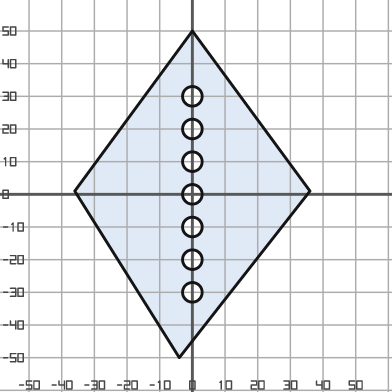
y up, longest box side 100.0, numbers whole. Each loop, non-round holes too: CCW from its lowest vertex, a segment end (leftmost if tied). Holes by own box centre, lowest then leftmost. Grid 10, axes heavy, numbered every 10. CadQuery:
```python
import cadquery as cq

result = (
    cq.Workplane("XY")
    .moveTo(-4.0, -50.0)
    .lineTo(36.0, 1.0)
    .lineTo(0.0, 50.0)
    .lineTo(-36.0, 1.0)
    .close()
    .moveTo(0.0, -30.0)
    .circle(3.0)
    .moveTo(0.0, -20.0)
    .circle(3.0)
    .moveTo(0.0, -10.0)
    .circle(3.0)
    .moveTo(0.0, 0.0)
    .circle(3.0)
    .moveTo(0.0, 10.0)
    .circle(3.0)
    .moveTo(0.0, 20.0)
    .circle(3.0)
    .moveTo(0.0, 30.0)
    .circle(3.0)
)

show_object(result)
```